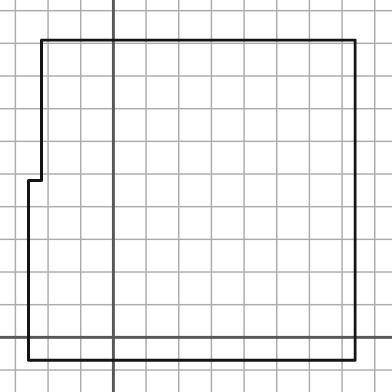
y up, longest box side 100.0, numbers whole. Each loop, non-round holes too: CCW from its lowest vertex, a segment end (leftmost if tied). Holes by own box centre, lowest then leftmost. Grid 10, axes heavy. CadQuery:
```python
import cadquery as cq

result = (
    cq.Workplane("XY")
    .moveTo(-26.0, -7.0)
    .lineTo(74.0, -7.0)
    .lineTo(74.0, 91.0)
    .lineTo(-22.0, 91.0)
    .lineTo(-22.0, 48.0)
    .lineTo(-26.0, 48.0)
    .close()
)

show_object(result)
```